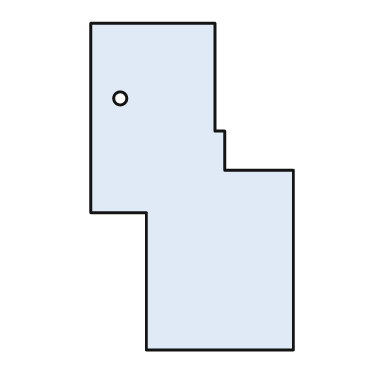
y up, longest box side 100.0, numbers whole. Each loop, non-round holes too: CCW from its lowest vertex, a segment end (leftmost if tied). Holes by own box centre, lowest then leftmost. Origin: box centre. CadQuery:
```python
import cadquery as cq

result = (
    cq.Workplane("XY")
    .moveTo(-14.0, -50.0)
    .lineTo(31.0, -50.0)
    .lineTo(31.0, 5.0)
    .lineTo(10.0, 5.0)
    .lineTo(10.0, 17.0)
    .lineTo(7.0, 17.0)
    .lineTo(7.0, 50.0)
    .lineTo(-31.0, 50.0)
    .lineTo(-31.0, -8.0)
    .lineTo(-14.0, -8.0)
    .close()
    .moveTo(-22.0, 27.0)
    .circle(2.0)
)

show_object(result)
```